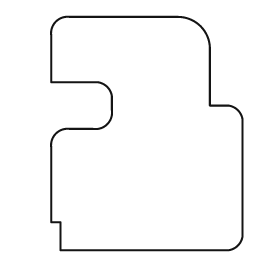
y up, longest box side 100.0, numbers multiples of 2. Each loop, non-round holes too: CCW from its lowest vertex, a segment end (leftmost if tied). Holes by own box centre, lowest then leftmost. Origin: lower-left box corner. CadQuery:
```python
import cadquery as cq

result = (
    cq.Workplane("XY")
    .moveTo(4.0, 0.0)
    .lineTo(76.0, 0.0)
    .threePointArc((80.0, 2.0), (82.0, 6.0))
    .lineTo(82.0, 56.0)
    .threePointArc((80.0, 60.0), (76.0, 62.0))
    .lineTo(68.0, 62.0)
    .lineTo(68.0, 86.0)
    .threePointArc((64.0, 96.0), (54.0, 100.0))
    .lineTo(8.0, 100.0)
    .threePointArc((2.0, 98.0), (0.0, 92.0))
    .lineTo(0.0, 72.0)
    .lineTo(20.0, 72.0)
    .threePointArc((24.0, 70.0), (26.0, 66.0))
    .lineTo(26.0, 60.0)
    .threePointArc((24.0, 54.0), (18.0, 52.0))
    .lineTo(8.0, 52.0)
    .threePointArc((2.0, 50.0), (0.0, 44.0))
    .lineTo(0.0, 12.0)
    .lineTo(4.0, 12.0)
    .close()
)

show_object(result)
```